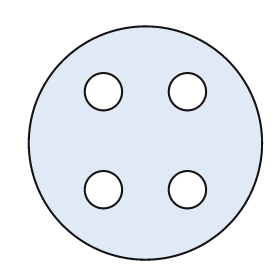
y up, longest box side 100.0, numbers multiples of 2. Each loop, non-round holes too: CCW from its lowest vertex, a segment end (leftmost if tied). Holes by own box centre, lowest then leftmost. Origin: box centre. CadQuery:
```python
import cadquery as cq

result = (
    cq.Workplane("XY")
    .moveTo(0.0, 0.0)
    .circle(50.0)
    .moveTo(-18.0, -20.0)
    .circle(8.0)
    .moveTo(18.0, -20.0)
    .circle(8.0)
    .moveTo(-18.0, 22.0)
    .circle(8.0)
    .moveTo(18.0, 22.0)
    .circle(8.0)
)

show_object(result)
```